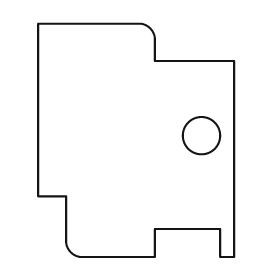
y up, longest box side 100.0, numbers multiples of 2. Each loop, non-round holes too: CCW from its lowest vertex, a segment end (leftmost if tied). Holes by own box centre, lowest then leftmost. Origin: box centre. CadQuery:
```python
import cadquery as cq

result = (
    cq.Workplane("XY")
    .moveTo(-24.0, -50.0)
    .lineTo(8.0, -50.0)
    .lineTo(8.0, -38.0)
    .lineTo(36.0, -38.0)
    .lineTo(36.0, -50.0)
    .lineTo(42.0, -50.0)
    .lineTo(42.0, 34.0)
    .lineTo(8.0, 34.0)
    .lineTo(8.0, 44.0)
    .threePointArc((6.0, 48.0), (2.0, 50.0))
    .lineTo(-42.0, 50.0)
    .lineTo(-42.0, -24.0)
    .lineTo(-30.0, -24.0)
    .lineTo(-30.0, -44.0)
    .threePointArc((-28.0, -48.0), (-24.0, -50.0))
    .close()
    .moveTo(28.0, 2.0)
    .circle(8.0)
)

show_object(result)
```